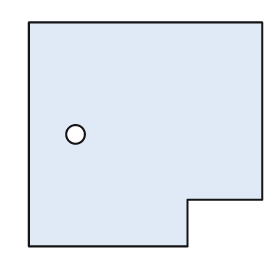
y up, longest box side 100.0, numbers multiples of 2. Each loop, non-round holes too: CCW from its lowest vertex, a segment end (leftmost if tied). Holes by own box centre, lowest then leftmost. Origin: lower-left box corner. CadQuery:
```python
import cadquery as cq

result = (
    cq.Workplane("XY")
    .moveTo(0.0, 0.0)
    .lineTo(68.0, 0.0)
    .lineTo(68.0, 20.0)
    .lineTo(100.0, 20.0)
    .lineTo(100.0, 96.0)
    .lineTo(0.0, 96.0)
    .close()
    .moveTo(20.0, 48.0)
    .circle(4.0)
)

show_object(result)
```